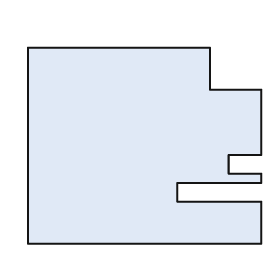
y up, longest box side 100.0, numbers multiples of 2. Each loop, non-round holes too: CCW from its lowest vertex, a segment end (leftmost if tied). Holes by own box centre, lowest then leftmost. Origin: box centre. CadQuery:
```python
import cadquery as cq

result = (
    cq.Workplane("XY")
    .moveTo(-50.0, -42.0)
    .lineTo(50.0, -42.0)
    .lineTo(50.0, -24.0)
    .lineTo(14.0, -24.0)
    .lineTo(14.0, -16.0)
    .lineTo(50.0, -16.0)
    .lineTo(50.0, -12.0)
    .lineTo(36.0, -12.0)
    .lineTo(36.0, -4.0)
    .lineTo(50.0, -4.0)
    .lineTo(50.0, 24.0)
    .lineTo(28.0, 24.0)
    .lineTo(28.0, 42.0)
    .lineTo(-50.0, 42.0)
    .close()
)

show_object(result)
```